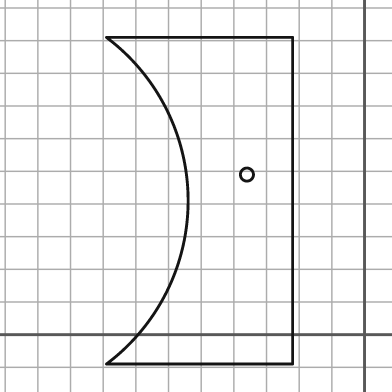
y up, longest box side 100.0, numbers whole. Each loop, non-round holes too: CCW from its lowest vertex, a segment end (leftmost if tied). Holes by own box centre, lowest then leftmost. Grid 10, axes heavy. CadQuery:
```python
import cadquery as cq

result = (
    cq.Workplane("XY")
    .moveTo(-79.0, -9.0)
    .lineTo(-22.0, -9.0)
    .lineTo(-22.0, 91.0)
    .lineTo(-79.0, 91.0)
    .threePointArc((-54.0, 41.0), (-79.0, -9.0))
    .close()
    .moveTo(-36.0, 49.0)
    .circle(2.0)
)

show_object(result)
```